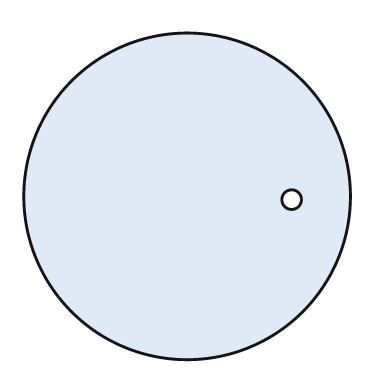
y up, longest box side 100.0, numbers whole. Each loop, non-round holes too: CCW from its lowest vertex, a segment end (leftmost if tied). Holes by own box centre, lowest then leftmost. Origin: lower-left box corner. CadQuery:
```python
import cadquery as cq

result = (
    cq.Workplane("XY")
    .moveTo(50.0, 50.0)
    .circle(50.0)
    .moveTo(82.0, 49.0)
    .circle(3.0)
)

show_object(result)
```